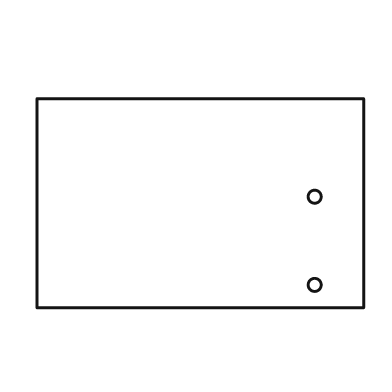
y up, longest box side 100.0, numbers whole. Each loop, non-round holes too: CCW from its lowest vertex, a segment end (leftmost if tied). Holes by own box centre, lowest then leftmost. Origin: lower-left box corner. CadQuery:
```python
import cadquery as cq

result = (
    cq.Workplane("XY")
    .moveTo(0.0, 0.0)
    .lineTo(100.0, 0.0)
    .lineTo(100.0, 64.0)
    .lineTo(0.0, 64.0)
    .close()
    .moveTo(85.0, 7.0)
    .circle(2.0)
    .moveTo(85.0, 34.0)
    .circle(2.0)
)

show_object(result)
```